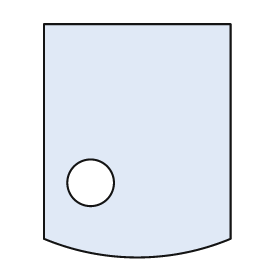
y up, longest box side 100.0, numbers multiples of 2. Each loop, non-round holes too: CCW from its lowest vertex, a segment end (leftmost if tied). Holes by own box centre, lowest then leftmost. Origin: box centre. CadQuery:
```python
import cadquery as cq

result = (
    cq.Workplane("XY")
    .moveTo(-40.0, -42.0)
    .threePointArc((0.0, -50.0), (40.0, -42.0))
    .lineTo(40.0, 50.0)
    .lineTo(-40.0, 50.0)
    .close()
    .moveTo(-20.0, -18.0)
    .circle(10.0)
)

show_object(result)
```